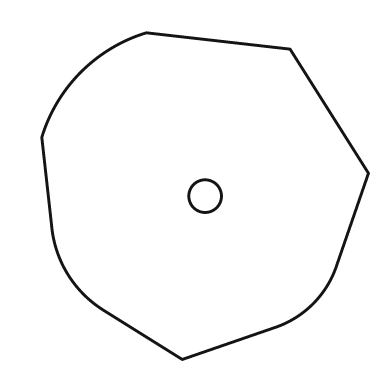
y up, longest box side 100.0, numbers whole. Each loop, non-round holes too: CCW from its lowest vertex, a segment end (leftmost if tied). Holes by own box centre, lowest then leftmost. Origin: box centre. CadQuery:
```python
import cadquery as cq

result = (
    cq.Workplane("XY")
    .moveTo(-7.0, -50.0)
    .lineTo(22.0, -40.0)
    .threePointArc((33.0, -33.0), (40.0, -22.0))
    .lineTo(50.0, 7.0)
    .lineTo(26.0, 45.0)
    .lineTo(-18.0, 50.0)
    .threePointArc((-38.0, 38.0), (-50.0, 18.0))
    .lineTo(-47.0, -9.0)
    .threePointArc((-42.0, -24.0), (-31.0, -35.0))
    .close()
    .moveTo(0.0, 0.0)
    .circle(5.0)
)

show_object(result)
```